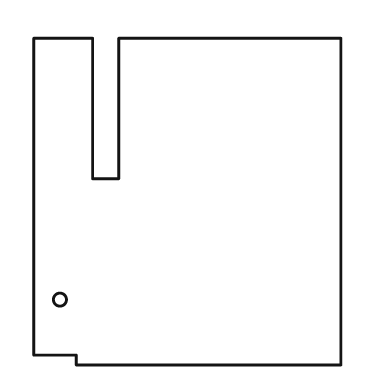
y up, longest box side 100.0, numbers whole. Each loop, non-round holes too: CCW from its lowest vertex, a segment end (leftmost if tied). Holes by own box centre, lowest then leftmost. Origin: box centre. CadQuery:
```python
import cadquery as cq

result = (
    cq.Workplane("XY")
    .moveTo(-34.0, -50.0)
    .lineTo(47.0, -50.0)
    .lineTo(47.0, 50.0)
    .lineTo(-21.0, 50.0)
    .lineTo(-21.0, 7.0)
    .lineTo(-29.0, 7.0)
    .lineTo(-29.0, 50.0)
    .lineTo(-47.0, 50.0)
    .lineTo(-47.0, -47.0)
    .lineTo(-34.0, -47.0)
    .close()
    .moveTo(-39.0, -30.0)
    .circle(2.0)
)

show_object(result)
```